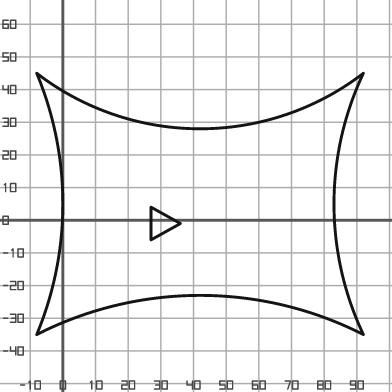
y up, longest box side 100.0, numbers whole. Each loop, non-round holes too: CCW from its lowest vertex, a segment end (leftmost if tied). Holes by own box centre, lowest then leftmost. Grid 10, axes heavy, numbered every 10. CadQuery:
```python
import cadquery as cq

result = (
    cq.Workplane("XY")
    .moveTo(-8.0, -35.0)
    .threePointArc((42.0, -23.0), (92.0, -35.0))
    .threePointArc((83.0, 5.0), (92.0, 45.0))
    .threePointArc((42.0, 28.0), (-8.0, 45.0))
    .threePointArc((0.0, 5.0), (-8.0, -35.0))
    .close()
    .moveTo(27.0, -6.0)
    .lineTo(36.0, -1.0)
    .lineTo(27.0, 4.0)
    .close()
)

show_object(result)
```